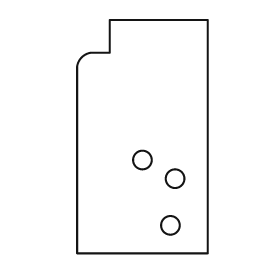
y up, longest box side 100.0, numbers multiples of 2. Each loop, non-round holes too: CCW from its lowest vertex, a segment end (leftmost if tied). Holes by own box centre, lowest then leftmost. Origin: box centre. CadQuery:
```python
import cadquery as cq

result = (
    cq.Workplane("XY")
    .moveTo(-28.0, -50.0)
    .lineTo(28.0, -50.0)
    .lineTo(28.0, 50.0)
    .lineTo(-14.0, 50.0)
    .lineTo(-14.0, 36.0)
    .lineTo(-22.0, 36.0)
    .threePointArc((-26.0, 34.0), (-28.0, 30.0))
    .close()
    .moveTo(12.0, -38.0)
    .circle(4.0)
    .moveTo(14.0, -18.0)
    .circle(4.0)
    .moveTo(0.0, -10.0)
    .circle(4.0)
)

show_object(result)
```